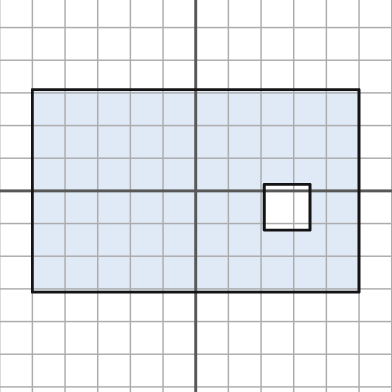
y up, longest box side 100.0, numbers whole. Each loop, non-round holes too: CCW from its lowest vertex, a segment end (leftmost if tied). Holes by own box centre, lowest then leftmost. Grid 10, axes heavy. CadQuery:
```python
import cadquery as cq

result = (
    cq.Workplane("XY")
    .moveTo(-50.0, -31.0)
    .lineTo(50.0, -31.0)
    .lineTo(50.0, 31.0)
    .lineTo(-50.0, 31.0)
    .close()
    .moveTo(21.0, -12.0)
    .lineTo(35.0, -12.0)
    .lineTo(35.0, 2.0)
    .lineTo(21.0, 2.0)
    .close()
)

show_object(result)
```